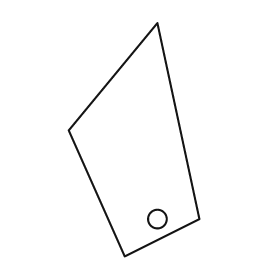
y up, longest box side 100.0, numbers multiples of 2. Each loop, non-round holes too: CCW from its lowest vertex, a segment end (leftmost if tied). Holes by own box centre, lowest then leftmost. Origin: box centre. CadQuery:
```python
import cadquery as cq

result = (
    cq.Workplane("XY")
    .moveTo(-4.0, -50.0)
    .lineTo(28.0, -34.0)
    .lineTo(10.0, 50.0)
    .lineTo(-28.0, 4.0)
    .close()
    .moveTo(10.0, -34.0)
    .circle(4.0)
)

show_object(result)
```